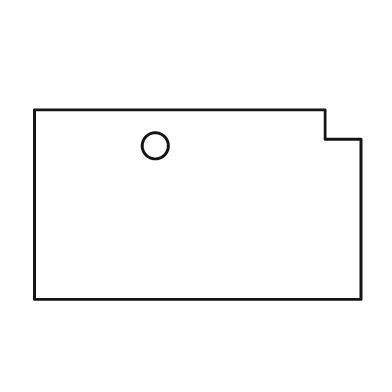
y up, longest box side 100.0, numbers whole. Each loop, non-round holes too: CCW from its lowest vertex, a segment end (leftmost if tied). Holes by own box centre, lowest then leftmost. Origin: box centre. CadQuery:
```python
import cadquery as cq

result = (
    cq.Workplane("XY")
    .moveTo(-50.0, -29.0)
    .lineTo(50.0, -29.0)
    .lineTo(50.0, 20.0)
    .lineTo(39.0, 20.0)
    .lineTo(39.0, 29.0)
    .lineTo(-50.0, 29.0)
    .close()
    .moveTo(-13.0, 18.0)
    .circle(4.0)
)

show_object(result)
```